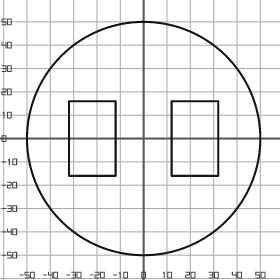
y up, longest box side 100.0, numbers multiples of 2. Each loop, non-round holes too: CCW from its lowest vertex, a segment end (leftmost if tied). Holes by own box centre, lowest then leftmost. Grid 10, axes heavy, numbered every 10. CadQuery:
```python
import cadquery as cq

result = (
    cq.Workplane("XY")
    .moveTo(0.0, 0.0)
    .circle(50.0)
    .moveTo(-32.0, -16.0)
    .lineTo(-12.0, -16.0)
    .lineTo(-12.0, 16.0)
    .lineTo(-32.0, 16.0)
    .close()
    .moveTo(12.0, -16.0)
    .lineTo(32.0, -16.0)
    .lineTo(32.0, 16.0)
    .lineTo(12.0, 16.0)
    .close()
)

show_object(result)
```